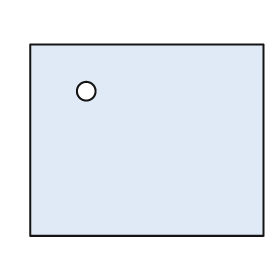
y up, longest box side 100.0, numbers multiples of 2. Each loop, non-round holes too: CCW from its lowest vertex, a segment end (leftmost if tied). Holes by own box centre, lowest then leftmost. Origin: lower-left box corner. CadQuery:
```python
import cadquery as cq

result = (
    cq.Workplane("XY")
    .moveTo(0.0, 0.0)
    .lineTo(100.0, 0.0)
    .lineTo(100.0, 82.0)
    .lineTo(0.0, 82.0)
    .close()
    .moveTo(24.0, 62.0)
    .circle(4.0)
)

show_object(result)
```